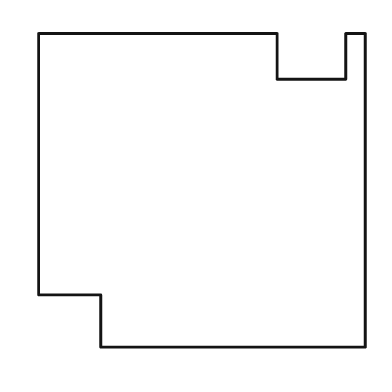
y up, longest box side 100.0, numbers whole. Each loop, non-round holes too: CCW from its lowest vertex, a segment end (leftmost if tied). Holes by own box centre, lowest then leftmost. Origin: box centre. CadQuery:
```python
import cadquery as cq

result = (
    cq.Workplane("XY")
    .moveTo(-31.0, -48.0)
    .lineTo(50.0, -48.0)
    .lineTo(50.0, 48.0)
    .lineTo(44.0, 48.0)
    .lineTo(44.0, 34.0)
    .lineTo(23.0, 34.0)
    .lineTo(23.0, 48.0)
    .lineTo(-50.0, 48.0)
    .lineTo(-50.0, -32.0)
    .lineTo(-31.0, -32.0)
    .close()
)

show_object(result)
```